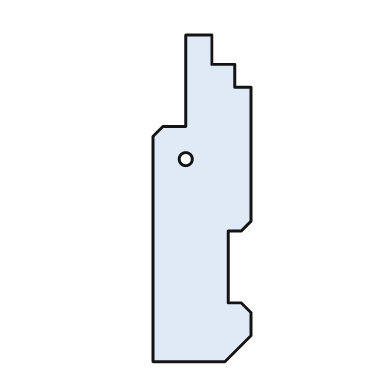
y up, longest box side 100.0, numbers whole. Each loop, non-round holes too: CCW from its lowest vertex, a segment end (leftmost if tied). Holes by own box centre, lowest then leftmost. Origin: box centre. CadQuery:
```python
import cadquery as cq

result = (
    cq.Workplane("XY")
    .moveTo(-15.0, -50.0)
    .lineTo(7.0, -50.0)
    .lineTo(15.0, -42.0)
    .lineTo(15.0, -35.0)
    .lineTo(12.0, -32.0)
    .lineTo(8.0, -32.0)
    .lineTo(8.0, -10.0)
    .lineTo(12.0, -10.0)
    .lineTo(15.0, -7.0)
    .lineTo(15.0, 34.0)
    .lineTo(10.0, 34.0)
    .lineTo(10.0, 41.0)
    .lineTo(3.0, 41.0)
    .lineTo(3.0, 50.0)
    .lineTo(-5.0, 50.0)
    .lineTo(-5.0, 22.0)
    .lineTo(-12.0, 22.0)
    .lineTo(-15.0, 19.0)
    .close()
    .moveTo(-5.0, 12.0)
    .circle(2.0)
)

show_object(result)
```